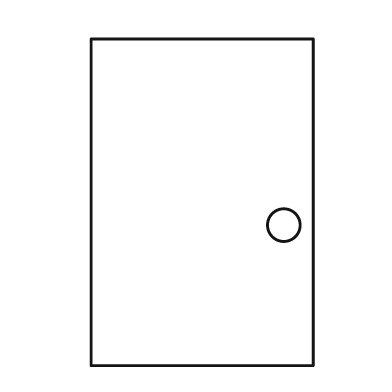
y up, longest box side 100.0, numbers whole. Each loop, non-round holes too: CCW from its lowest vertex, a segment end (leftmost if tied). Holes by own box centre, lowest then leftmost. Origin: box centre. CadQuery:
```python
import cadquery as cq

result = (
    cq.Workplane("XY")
    .moveTo(-34.0, -50.0)
    .lineTo(34.0, -50.0)
    .lineTo(34.0, 50.0)
    .lineTo(-34.0, 50.0)
    .close()
    .moveTo(25.0, -7.0)
    .circle(5.0)
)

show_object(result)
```